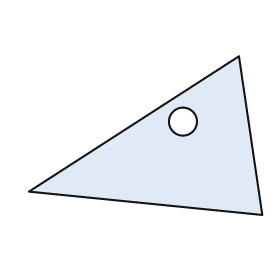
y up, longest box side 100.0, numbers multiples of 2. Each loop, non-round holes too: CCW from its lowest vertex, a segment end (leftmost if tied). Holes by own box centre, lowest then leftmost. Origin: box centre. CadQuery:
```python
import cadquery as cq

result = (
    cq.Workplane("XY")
    .moveTo(50.0, -34.0)
    .lineTo(40.0, 34.0)
    .lineTo(-50.0, -24.0)
    .close()
    .moveTo(16.0, 6.0)
    .circle(6.0)
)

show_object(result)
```